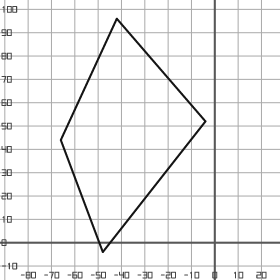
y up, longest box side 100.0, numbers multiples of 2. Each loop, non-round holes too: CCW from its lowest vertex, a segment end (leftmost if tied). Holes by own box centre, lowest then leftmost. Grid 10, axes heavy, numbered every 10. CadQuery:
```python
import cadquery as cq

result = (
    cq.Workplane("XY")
    .moveTo(-48.0, -4.0)
    .lineTo(-4.0, 52.0)
    .lineTo(-42.0, 96.0)
    .lineTo(-66.0, 44.0)
    .close()
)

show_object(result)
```